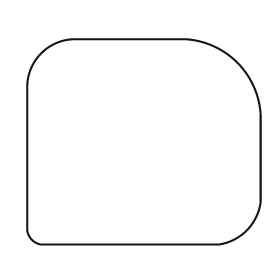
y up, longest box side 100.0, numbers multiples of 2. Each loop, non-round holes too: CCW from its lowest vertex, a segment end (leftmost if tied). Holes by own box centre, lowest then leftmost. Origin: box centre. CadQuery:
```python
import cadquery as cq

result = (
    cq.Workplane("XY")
    .moveTo(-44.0, -44.0)
    .lineTo(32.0, -44.0)
    .threePointArc((44.0, -38.0), (50.0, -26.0))
    .lineTo(50.0, 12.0)
    .threePointArc((40.0, 34.0), (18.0, 44.0))
    .lineTo(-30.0, 44.0)
    .threePointArc((-44.0, 38.0), (-50.0, 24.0))
    .lineTo(-50.0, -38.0)
    .threePointArc((-48.0, -42.0), (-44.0, -44.0))
    .close()
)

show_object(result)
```